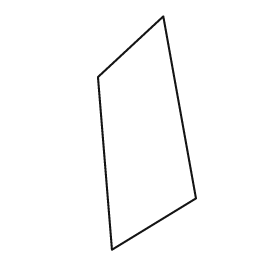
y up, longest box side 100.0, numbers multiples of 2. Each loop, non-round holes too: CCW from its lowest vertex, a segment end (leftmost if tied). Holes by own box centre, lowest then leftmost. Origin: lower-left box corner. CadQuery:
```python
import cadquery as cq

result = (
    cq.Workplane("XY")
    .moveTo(6.0, 0.0)
    .lineTo(42.0, 22.0)
    .lineTo(28.0, 100.0)
    .lineTo(0.0, 74.0)
    .close()
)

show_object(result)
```